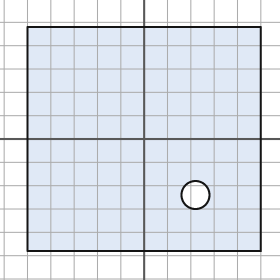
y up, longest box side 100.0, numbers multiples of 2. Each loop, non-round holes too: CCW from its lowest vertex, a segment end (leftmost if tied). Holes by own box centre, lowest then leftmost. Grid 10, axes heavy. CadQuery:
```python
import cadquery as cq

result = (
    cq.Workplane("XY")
    .moveTo(-50.0, -48.0)
    .lineTo(50.0, -48.0)
    .lineTo(50.0, 48.0)
    .lineTo(-50.0, 48.0)
    .close()
    .moveTo(22.0, -24.0)
    .circle(6.0)
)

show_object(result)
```